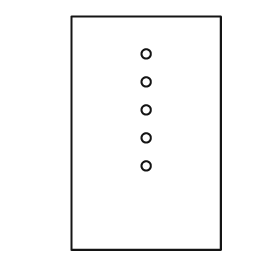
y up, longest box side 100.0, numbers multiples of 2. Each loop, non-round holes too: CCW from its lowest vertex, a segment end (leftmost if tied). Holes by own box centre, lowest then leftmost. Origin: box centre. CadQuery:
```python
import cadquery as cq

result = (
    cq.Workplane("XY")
    .moveTo(-32.0, -50.0)
    .lineTo(32.0, -50.0)
    .lineTo(32.0, 50.0)
    .lineTo(-32.0, 50.0)
    .close()
    .moveTo(0.0, -14.0)
    .circle(2.0)
    .moveTo(0.0, -2.0)
    .circle(2.0)
    .moveTo(0.0, 10.0)
    .circle(2.0)
    .moveTo(0.0, 22.0)
    .circle(2.0)
    .moveTo(0.0, 34.0)
    .circle(2.0)
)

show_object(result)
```